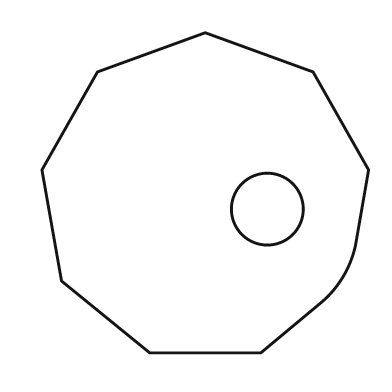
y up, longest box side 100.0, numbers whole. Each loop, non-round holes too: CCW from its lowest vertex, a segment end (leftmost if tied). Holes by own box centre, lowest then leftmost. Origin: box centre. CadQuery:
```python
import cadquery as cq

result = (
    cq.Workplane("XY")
    .moveTo(-17.0, -49.0)
    .lineTo(17.0, -49.0)
    .lineTo(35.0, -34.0)
    .threePointArc((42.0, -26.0), (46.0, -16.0))
    .lineTo(50.0, 7.0)
    .lineTo(33.0, 37.0)
    .lineTo(0.0, 49.0)
    .lineTo(-33.0, 37.0)
    .lineTo(-50.0, 7.0)
    .lineTo(-44.0, -27.0)
    .close()
    .moveTo(19.0, -5.0)
    .circle(11.0)
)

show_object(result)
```